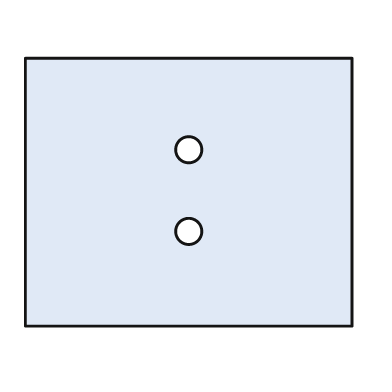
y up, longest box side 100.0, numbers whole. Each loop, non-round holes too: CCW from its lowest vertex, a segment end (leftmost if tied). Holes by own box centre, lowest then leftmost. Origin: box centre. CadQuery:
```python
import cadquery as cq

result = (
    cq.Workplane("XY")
    .moveTo(-50.0, -41.0)
    .lineTo(50.0, -41.0)
    .lineTo(50.0, 41.0)
    .lineTo(-50.0, 41.0)
    .close()
    .moveTo(0.0, -12.0)
    .circle(4.0)
    .moveTo(0.0, 13.0)
    .circle(4.0)
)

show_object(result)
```